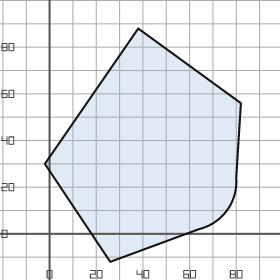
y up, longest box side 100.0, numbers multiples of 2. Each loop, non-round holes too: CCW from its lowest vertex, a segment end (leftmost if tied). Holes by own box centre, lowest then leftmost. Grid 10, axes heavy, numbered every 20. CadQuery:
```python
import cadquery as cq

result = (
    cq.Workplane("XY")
    .moveTo(26.0, -12.0)
    .lineTo(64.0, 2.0)
    .threePointArc((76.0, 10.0), (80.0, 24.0))
    .lineTo(82.0, 56.0)
    .lineTo(38.0, 88.0)
    .lineTo(-2.0, 30.0)
    .close()
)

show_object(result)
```